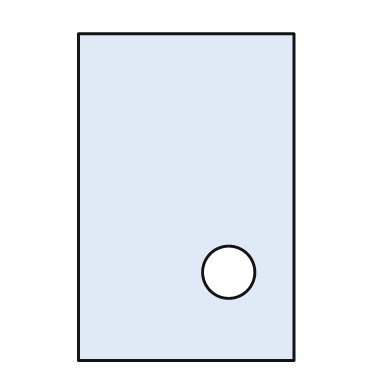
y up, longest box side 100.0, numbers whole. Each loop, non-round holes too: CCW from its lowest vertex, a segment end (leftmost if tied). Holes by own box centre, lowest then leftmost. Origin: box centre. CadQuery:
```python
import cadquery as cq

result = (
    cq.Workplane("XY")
    .moveTo(-33.0, -50.0)
    .lineTo(33.0, -50.0)
    .lineTo(33.0, 50.0)
    .lineTo(-33.0, 50.0)
    .close()
    .moveTo(13.0, -23.0)
    .circle(8.0)
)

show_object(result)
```